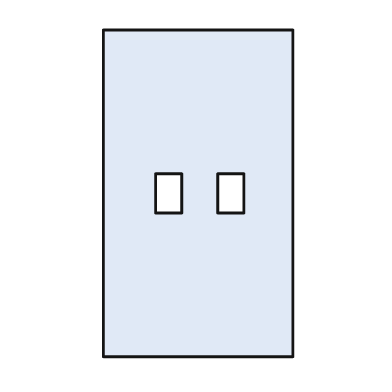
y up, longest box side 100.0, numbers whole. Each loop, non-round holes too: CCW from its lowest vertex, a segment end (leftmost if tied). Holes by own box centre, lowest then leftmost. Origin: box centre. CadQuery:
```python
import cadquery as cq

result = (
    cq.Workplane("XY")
    .moveTo(-29.0, -50.0)
    .lineTo(29.0, -50.0)
    .lineTo(29.0, 50.0)
    .lineTo(-29.0, 50.0)
    .close()
    .moveTo(-13.0, -6.0)
    .lineTo(-5.0, -6.0)
    .lineTo(-5.0, 6.0)
    .lineTo(-13.0, 6.0)
    .close()
    .moveTo(6.0, -6.0)
    .lineTo(14.0, -6.0)
    .lineTo(14.0, 6.0)
    .lineTo(6.0, 6.0)
    .close()
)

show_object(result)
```